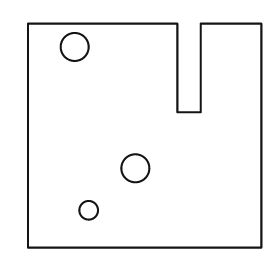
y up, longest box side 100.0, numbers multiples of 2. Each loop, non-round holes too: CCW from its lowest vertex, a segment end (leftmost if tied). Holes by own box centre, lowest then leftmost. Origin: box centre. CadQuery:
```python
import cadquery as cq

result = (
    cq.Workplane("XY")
    .moveTo(-50.0, -48.0)
    .lineTo(50.0, -48.0)
    .lineTo(50.0, 48.0)
    .lineTo(24.0, 48.0)
    .lineTo(24.0, 10.0)
    .lineTo(14.0, 10.0)
    .lineTo(14.0, 48.0)
    .lineTo(-50.0, 48.0)
    .close()
    .moveTo(-24.0, -32.0)
    .circle(4.0)
    .moveTo(-4.0, -14.0)
    .circle(6.0)
    .moveTo(-30.0, 38.0)
    .circle(6.0)
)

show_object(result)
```